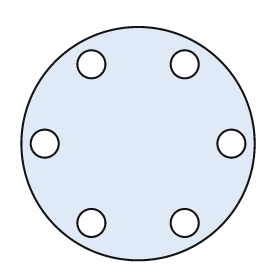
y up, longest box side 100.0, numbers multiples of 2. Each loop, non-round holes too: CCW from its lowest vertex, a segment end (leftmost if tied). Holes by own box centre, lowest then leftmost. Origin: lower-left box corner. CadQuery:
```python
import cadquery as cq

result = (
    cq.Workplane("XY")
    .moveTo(50.0, 50.0)
    .circle(50.0)
    .moveTo(30.0, 16.0)
    .circle(6.0)
    .moveTo(70.0, 16.0)
    .circle(6.0)
    .moveTo(10.0, 50.0)
    .circle(6.0)
    .moveTo(90.0, 50.0)
    .circle(6.0)
    .moveTo(30.0, 84.0)
    .circle(6.0)
    .moveTo(70.0, 84.0)
    .circle(6.0)
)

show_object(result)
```